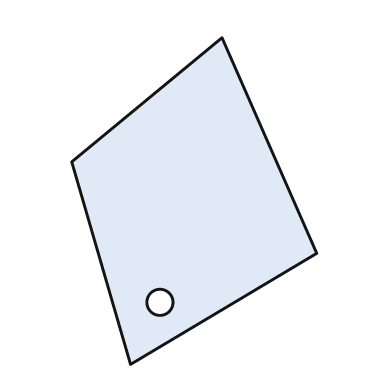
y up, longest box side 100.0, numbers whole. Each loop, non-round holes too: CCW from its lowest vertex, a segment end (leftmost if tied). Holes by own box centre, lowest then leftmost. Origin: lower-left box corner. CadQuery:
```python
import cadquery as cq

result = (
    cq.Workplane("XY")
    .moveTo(18.0, 0.0)
    .lineTo(75.0, 34.0)
    .lineTo(46.0, 100.0)
    .lineTo(0.0, 62.0)
    .close()
    .moveTo(27.0, 19.0)
    .circle(4.0)
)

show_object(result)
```